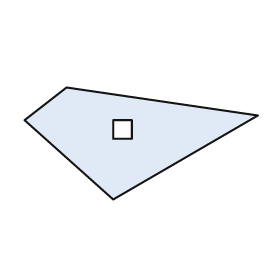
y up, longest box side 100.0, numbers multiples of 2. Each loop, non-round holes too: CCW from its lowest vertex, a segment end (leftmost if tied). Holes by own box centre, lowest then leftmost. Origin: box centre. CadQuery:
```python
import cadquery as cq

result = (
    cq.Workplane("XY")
    .moveTo(-12.0, -24.0)
    .lineTo(50.0, 12.0)
    .lineTo(-32.0, 24.0)
    .lineTo(-50.0, 10.0)
    .close()
    .moveTo(-12.0, 2.0)
    .lineTo(-4.0, 2.0)
    .lineTo(-4.0, 10.0)
    .lineTo(-12.0, 10.0)
    .close()
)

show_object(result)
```